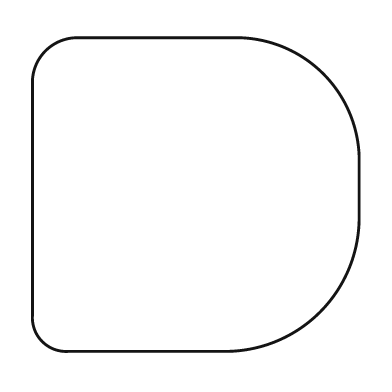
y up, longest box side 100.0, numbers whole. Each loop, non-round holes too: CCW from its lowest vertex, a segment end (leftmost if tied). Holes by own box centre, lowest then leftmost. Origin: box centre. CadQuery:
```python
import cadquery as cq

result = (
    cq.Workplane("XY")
    .moveTo(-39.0, -48.0)
    .lineTo(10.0, -48.0)
    .threePointArc((38.0, -36.0), (50.0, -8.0))
    .lineTo(50.0, 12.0)
    .threePointArc((39.0, 37.0), (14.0, 48.0))
    .lineTo(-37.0, 48.0)
    .threePointArc((-46.0, 44.0), (-50.0, 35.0))
    .lineTo(-50.0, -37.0)
    .threePointArc((-47.0, -45.0), (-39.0, -48.0))
    .close()
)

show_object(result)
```